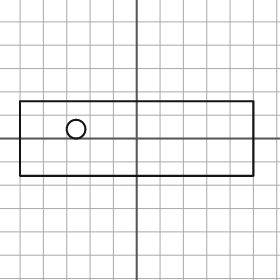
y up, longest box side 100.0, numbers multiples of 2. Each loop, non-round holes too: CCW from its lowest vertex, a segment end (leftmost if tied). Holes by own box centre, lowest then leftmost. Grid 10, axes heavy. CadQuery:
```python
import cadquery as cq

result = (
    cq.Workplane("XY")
    .moveTo(-50.0, -16.0)
    .lineTo(50.0, -16.0)
    .lineTo(50.0, 16.0)
    .lineTo(-50.0, 16.0)
    .close()
    .moveTo(-26.0, 4.0)
    .circle(4.0)
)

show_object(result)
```